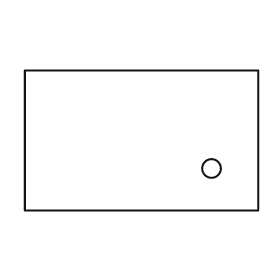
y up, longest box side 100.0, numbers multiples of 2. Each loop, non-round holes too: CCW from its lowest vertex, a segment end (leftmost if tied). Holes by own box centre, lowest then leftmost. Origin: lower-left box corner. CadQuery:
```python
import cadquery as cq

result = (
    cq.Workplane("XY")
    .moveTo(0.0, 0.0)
    .lineTo(100.0, 0.0)
    .lineTo(100.0, 60.0)
    .lineTo(0.0, 60.0)
    .close()
    .moveTo(80.0, 18.0)
    .circle(4.0)
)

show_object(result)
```